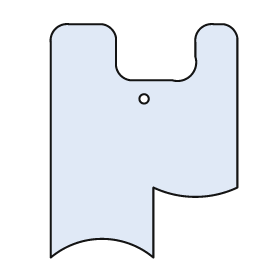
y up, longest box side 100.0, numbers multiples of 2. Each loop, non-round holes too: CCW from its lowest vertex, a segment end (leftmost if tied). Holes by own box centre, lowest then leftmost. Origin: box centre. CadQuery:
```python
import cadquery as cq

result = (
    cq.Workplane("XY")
    .moveTo(-40.0, -50.0)
    .threePointArc((-18.0, -42.0), (4.0, -50.0))
    .lineTo(4.0, -20.0)
    .threePointArc((22.0, -24.0), (40.0, -20.0))
    .lineTo(40.0, 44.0)
    .threePointArc((38.0, 48.0), (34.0, 50.0))
    .lineTo(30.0, 50.0)
    .threePointArc((24.0, 48.0), (22.0, 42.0))
    .lineTo(22.0, 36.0)
    .threePointArc((20.0, 28.0), (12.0, 26.0))
    .lineTo(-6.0, 26.0)
    .threePointArc((-10.0, 28.0), (-12.0, 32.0))
    .lineTo(-12.0, 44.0)
    .threePointArc((-14.0, 48.0), (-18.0, 50.0))
    .lineTo(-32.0, 50.0)
    .threePointArc((-38.0, 48.0), (-40.0, 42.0))
    .close()
    .moveTo(0.0, 18.0)
    .circle(2.0)
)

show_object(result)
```